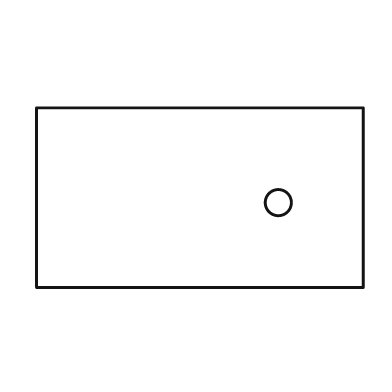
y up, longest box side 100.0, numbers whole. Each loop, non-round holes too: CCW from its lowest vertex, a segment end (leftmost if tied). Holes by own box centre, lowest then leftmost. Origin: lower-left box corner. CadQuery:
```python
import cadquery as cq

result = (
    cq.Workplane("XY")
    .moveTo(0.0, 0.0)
    .lineTo(100.0, 0.0)
    .lineTo(100.0, 55.0)
    .lineTo(0.0, 55.0)
    .close()
    .moveTo(74.0, 26.0)
    .circle(4.0)
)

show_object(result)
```